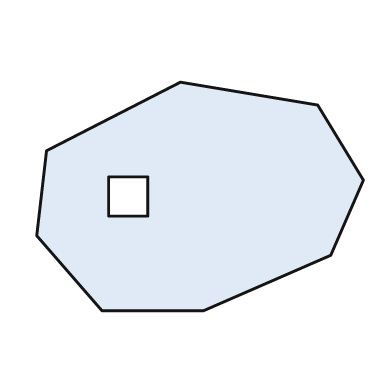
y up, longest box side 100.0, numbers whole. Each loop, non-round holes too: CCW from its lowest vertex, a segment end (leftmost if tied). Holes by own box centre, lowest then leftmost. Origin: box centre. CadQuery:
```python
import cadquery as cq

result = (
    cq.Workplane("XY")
    .moveTo(-30.0, -35.0)
    .lineTo(1.0, -35.0)
    .lineTo(40.0, -18.0)
    .lineTo(50.0, 5.0)
    .lineTo(36.0, 28.0)
    .lineTo(-6.0, 35.0)
    .lineTo(-47.0, 14.0)
    .lineTo(-50.0, -12.0)
    .close()
    .moveTo(-28.0, -6.0)
    .lineTo(-16.0, -6.0)
    .lineTo(-16.0, 6.0)
    .lineTo(-28.0, 6.0)
    .close()
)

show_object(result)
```